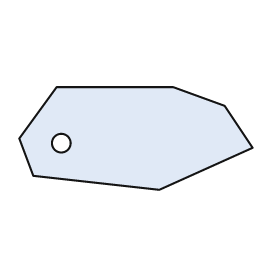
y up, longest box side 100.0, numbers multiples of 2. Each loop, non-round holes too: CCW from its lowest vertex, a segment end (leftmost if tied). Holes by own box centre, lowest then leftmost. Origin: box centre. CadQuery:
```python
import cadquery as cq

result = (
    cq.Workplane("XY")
    .moveTo(10.0, -22.0)
    .lineTo(50.0, -4.0)
    .lineTo(38.0, 14.0)
    .lineTo(16.0, 22.0)
    .lineTo(-34.0, 22.0)
    .lineTo(-50.0, 0.0)
    .lineTo(-44.0, -16.0)
    .close()
    .moveTo(-32.0, -2.0)
    .circle(4.0)
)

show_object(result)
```